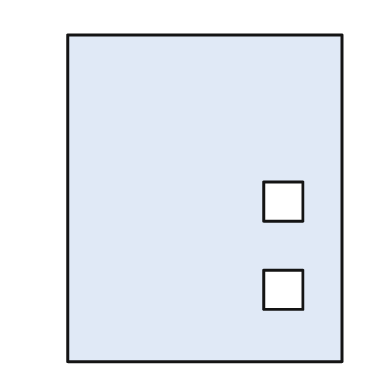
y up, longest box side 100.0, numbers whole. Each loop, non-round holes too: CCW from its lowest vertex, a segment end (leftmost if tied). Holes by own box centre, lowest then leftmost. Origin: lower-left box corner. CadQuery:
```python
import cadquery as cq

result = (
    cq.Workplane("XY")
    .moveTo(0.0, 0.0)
    .lineTo(84.0, 0.0)
    .lineTo(84.0, 100.0)
    .lineTo(0.0, 100.0)
    .close()
    .moveTo(60.0, 16.0)
    .lineTo(72.0, 16.0)
    .lineTo(72.0, 28.0)
    .lineTo(60.0, 28.0)
    .close()
    .moveTo(60.0, 43.0)
    .lineTo(72.0, 43.0)
    .lineTo(72.0, 55.0)
    .lineTo(60.0, 55.0)
    .close()
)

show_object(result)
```